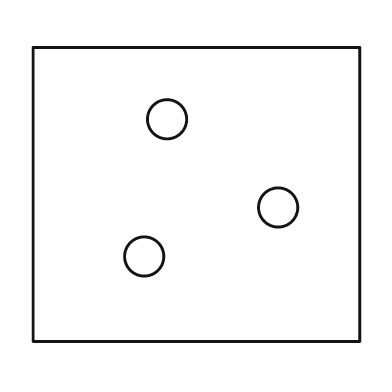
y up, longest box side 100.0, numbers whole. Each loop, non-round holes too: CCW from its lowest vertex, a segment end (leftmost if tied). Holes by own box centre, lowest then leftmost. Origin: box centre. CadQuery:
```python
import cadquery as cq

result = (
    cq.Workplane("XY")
    .moveTo(-50.0, -45.0)
    .lineTo(50.0, -45.0)
    .lineTo(50.0, 45.0)
    .lineTo(-50.0, 45.0)
    .close()
    .moveTo(-16.0, -19.0)
    .circle(6.0)
    .moveTo(25.0, -4.0)
    .circle(6.0)
    .moveTo(-9.0, 23.0)
    .circle(6.0)
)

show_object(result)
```